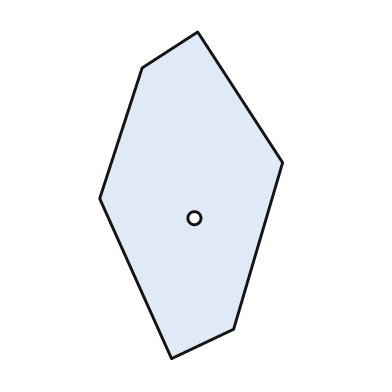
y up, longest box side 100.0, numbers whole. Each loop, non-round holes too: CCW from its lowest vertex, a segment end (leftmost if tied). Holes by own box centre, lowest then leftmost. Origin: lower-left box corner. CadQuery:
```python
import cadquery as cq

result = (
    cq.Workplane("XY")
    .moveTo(22.0, 0.0)
    .lineTo(41.0, 9.0)
    .lineTo(56.0, 60.0)
    .lineTo(30.0, 100.0)
    .lineTo(13.0, 89.0)
    .lineTo(0.0, 49.0)
    .close()
    .moveTo(29.0, 43.0)
    .circle(2.0)
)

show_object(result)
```